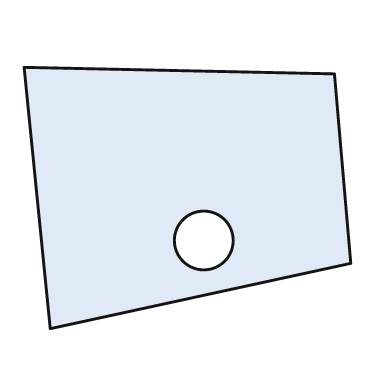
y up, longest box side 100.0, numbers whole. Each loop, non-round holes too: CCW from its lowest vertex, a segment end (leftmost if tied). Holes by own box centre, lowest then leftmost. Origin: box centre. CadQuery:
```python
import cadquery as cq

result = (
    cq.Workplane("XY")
    .moveTo(-42.0, -40.0)
    .lineTo(50.0, -20.0)
    .lineTo(45.0, 38.0)
    .lineTo(-50.0, 40.0)
    .close()
    .moveTo(5.0, -13.0)
    .circle(9.0)
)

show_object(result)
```